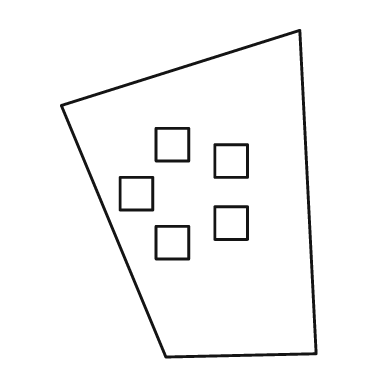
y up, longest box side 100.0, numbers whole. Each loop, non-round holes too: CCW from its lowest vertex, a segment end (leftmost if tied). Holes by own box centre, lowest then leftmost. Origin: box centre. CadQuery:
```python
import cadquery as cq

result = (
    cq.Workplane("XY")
    .moveTo(-7.0, -50.0)
    .lineTo(39.0, -49.0)
    .lineTo(34.0, 50.0)
    .lineTo(-39.0, 27.0)
    .close()
    .moveTo(-10.0, -20.0)
    .lineTo(0.0, -20.0)
    .lineTo(0.0, -10.0)
    .lineTo(-10.0, -10.0)
    .close()
    .moveTo(8.0, -14.0)
    .lineTo(18.0, -14.0)
    .lineTo(18.0, -4.0)
    .lineTo(8.0, -4.0)
    .close()
    .moveTo(-21.0, -5.0)
    .lineTo(-11.0, -5.0)
    .lineTo(-11.0, 5.0)
    .lineTo(-21.0, 5.0)
    .close()
    .moveTo(8.0, 5.0)
    .lineTo(18.0, 5.0)
    .lineTo(18.0, 15.0)
    .lineTo(8.0, 15.0)
    .close()
    .moveTo(-10.0, 10.0)
    .lineTo(0.0, 10.0)
    .lineTo(0.0, 20.0)
    .lineTo(-10.0, 20.0)
    .close()
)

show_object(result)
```